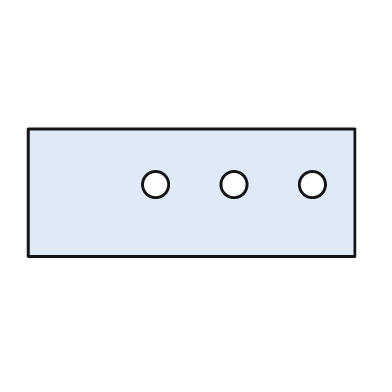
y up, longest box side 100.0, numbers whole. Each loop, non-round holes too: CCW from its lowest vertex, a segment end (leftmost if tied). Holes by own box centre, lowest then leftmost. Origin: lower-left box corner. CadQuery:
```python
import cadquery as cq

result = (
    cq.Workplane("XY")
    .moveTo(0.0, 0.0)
    .lineTo(100.0, 0.0)
    .lineTo(100.0, 39.0)
    .lineTo(0.0, 39.0)
    .close()
    .moveTo(39.0, 22.0)
    .circle(4.0)
    .moveTo(63.0, 22.0)
    .circle(4.0)
    .moveTo(87.0, 22.0)
    .circle(4.0)
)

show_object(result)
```